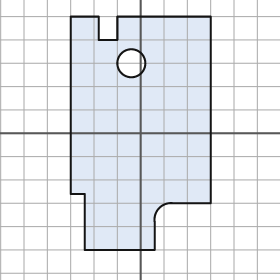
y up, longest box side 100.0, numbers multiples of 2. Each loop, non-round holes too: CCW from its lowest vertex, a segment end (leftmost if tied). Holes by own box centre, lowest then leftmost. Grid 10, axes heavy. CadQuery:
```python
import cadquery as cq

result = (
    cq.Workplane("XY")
    .moveTo(-24.0, -50.0)
    .lineTo(6.0, -50.0)
    .lineTo(6.0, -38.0)
    .threePointArc((8.0, -32.0), (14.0, -30.0))
    .lineTo(30.0, -30.0)
    .lineTo(30.0, 50.0)
    .lineTo(-10.0, 50.0)
    .lineTo(-10.0, 40.0)
    .lineTo(-18.0, 40.0)
    .lineTo(-18.0, 50.0)
    .lineTo(-30.0, 50.0)
    .lineTo(-30.0, -26.0)
    .lineTo(-24.0, -26.0)
    .close()
    .moveTo(-4.0, 30.0)
    .circle(6.0)
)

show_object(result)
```